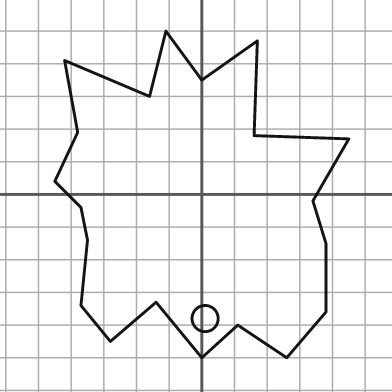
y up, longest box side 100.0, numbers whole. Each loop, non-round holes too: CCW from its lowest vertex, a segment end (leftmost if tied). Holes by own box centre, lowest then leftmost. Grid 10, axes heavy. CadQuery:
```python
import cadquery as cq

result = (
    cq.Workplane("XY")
    .moveTo(0.0, -50.0)
    .lineTo(11.0, -40.0)
    .lineTo(26.0, -50.0)
    .lineTo(38.0, -36.0)
    .lineTo(38.0, -15.0)
    .lineTo(34.0, -2.0)
    .lineTo(45.0, 17.0)
    .lineTo(16.0, 18.0)
    .lineTo(17.0, 47.0)
    .lineTo(0.0, 35.0)
    .lineTo(-11.0, 50.0)
    .lineTo(-16.0, 30.0)
    .lineTo(-42.0, 41.0)
    .lineTo(-38.0, 19.0)
    .lineTo(-45.0, 4.0)
    .lineTo(-37.0, -4.0)
    .lineTo(-35.0, -14.0)
    .lineTo(-37.0, -34.0)
    .lineTo(-28.0, -45.0)
    .lineTo(-14.0, -33.0)
    .close()
    .moveTo(1.0, -38.0)
    .circle(4.0)
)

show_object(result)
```